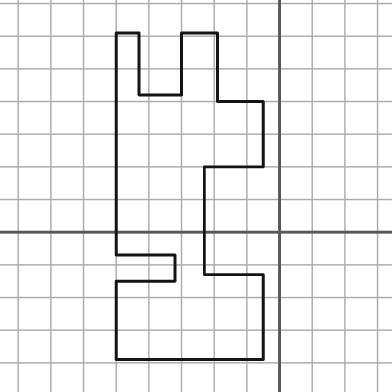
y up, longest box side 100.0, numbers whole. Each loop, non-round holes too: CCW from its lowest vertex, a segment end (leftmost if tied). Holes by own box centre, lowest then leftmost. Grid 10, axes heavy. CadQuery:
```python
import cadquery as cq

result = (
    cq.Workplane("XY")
    .moveTo(-50.0, -39.0)
    .lineTo(-5.0, -39.0)
    .lineTo(-5.0, -13.0)
    .lineTo(-23.0, -13.0)
    .lineTo(-23.0, 20.0)
    .lineTo(-5.0, 20.0)
    .lineTo(-5.0, 40.0)
    .lineTo(-19.0, 40.0)
    .lineTo(-19.0, 61.0)
    .lineTo(-30.0, 61.0)
    .lineTo(-30.0, 42.0)
    .lineTo(-43.0, 42.0)
    .lineTo(-43.0, 61.0)
    .lineTo(-50.0, 61.0)
    .lineTo(-50.0, -7.0)
    .lineTo(-32.0, -7.0)
    .lineTo(-32.0, -15.0)
    .lineTo(-50.0, -15.0)
    .close()
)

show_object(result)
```